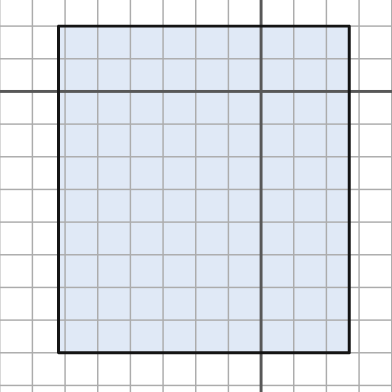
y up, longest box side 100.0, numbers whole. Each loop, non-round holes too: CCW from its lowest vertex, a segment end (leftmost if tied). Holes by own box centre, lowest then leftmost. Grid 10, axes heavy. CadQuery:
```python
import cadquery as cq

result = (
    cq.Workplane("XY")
    .moveTo(-62.0, -80.0)
    .lineTo(27.0, -80.0)
    .lineTo(27.0, 20.0)
    .lineTo(-62.0, 20.0)
    .close()
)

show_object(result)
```